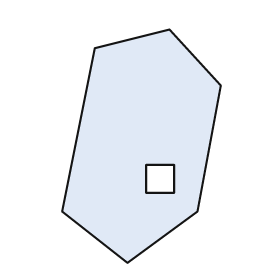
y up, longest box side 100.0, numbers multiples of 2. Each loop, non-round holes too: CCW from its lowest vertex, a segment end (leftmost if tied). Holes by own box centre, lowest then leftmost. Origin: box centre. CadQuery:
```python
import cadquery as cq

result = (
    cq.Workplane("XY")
    .moveTo(-6.0, -50.0)
    .lineTo(24.0, -28.0)
    .lineTo(34.0, 26.0)
    .lineTo(12.0, 50.0)
    .lineTo(-20.0, 42.0)
    .lineTo(-34.0, -28.0)
    .close()
    .moveTo(2.0, -20.0)
    .lineTo(14.0, -20.0)
    .lineTo(14.0, -8.0)
    .lineTo(2.0, -8.0)
    .close()
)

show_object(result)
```